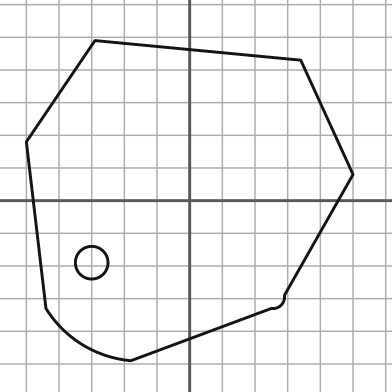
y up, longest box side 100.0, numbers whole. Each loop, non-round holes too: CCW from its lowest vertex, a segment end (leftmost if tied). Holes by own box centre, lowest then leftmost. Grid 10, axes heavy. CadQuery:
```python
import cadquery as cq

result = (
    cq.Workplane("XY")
    .moveTo(-18.0, -49.0)
    .lineTo(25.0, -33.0)
    .threePointArc((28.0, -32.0), (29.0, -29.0))
    .lineTo(50.0, 8.0)
    .lineTo(34.0, 43.0)
    .lineTo(-29.0, 49.0)
    .lineTo(-50.0, 18.0)
    .lineTo(-44.0, -33.0)
    .threePointArc((-33.0, -44.0), (-18.0, -49.0))
    .close()
    .moveTo(-30.0, -19.0)
    .circle(5.0)
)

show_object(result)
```